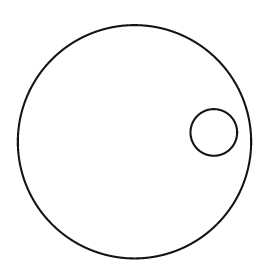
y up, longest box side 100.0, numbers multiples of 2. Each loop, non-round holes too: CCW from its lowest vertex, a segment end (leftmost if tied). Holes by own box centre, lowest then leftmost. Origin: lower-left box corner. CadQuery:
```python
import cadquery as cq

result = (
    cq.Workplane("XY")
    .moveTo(50.0, 50.0)
    .circle(50.0)
    .moveTo(84.0, 54.0)
    .circle(10.0)
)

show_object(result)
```